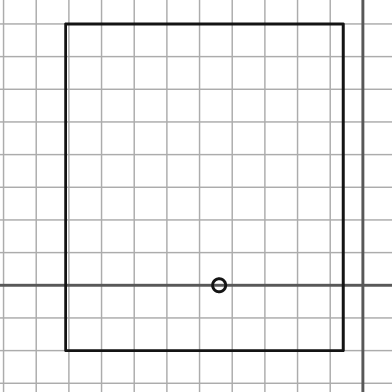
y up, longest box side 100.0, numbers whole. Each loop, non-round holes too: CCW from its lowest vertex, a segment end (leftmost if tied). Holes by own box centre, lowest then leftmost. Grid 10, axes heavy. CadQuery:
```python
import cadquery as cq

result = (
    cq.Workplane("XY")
    .moveTo(-91.0, -20.0)
    .lineTo(-6.0, -20.0)
    .lineTo(-6.0, 80.0)
    .lineTo(-91.0, 80.0)
    .close()
    .moveTo(-44.0, 0.0)
    .circle(2.0)
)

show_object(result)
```